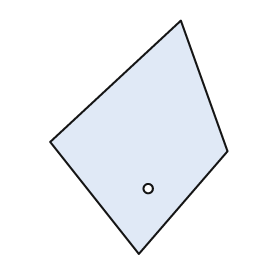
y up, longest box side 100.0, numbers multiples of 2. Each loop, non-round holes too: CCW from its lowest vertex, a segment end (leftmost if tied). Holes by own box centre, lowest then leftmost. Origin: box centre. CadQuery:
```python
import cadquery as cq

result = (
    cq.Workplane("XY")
    .moveTo(0.0, -50.0)
    .lineTo(38.0, -6.0)
    .lineTo(18.0, 50.0)
    .lineTo(-38.0, -2.0)
    .close()
    .moveTo(4.0, -22.0)
    .circle(2.0)
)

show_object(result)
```